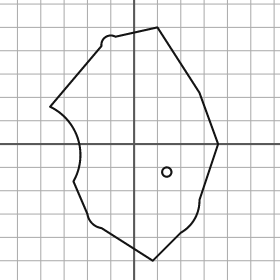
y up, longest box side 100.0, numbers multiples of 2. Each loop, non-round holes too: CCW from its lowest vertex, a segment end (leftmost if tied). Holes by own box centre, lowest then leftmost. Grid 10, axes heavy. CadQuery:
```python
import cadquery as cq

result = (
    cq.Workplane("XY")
    .moveTo(8.0, -50.0)
    .lineTo(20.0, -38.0)
    .threePointArc((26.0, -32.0), (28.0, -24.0))
    .lineTo(36.0, 0.0)
    .lineTo(28.0, 22.0)
    .lineTo(10.0, 50.0)
    .lineTo(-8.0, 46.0)
    .threePointArc((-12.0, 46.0), (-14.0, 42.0))
    .lineTo(-36.0, 16.0)
    .threePointArc((-24.0, 2.0), (-26.0, -16.0))
    .lineTo(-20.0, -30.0)
    .threePointArc((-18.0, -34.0), (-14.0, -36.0))
    .close()
    .moveTo(14.0, -12.0)
    .circle(2.0)
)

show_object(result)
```